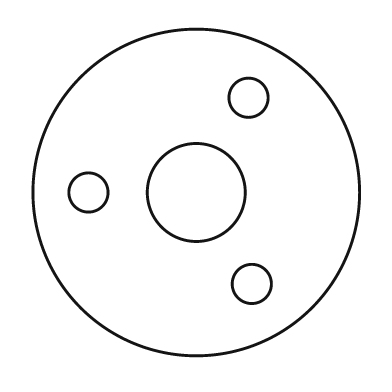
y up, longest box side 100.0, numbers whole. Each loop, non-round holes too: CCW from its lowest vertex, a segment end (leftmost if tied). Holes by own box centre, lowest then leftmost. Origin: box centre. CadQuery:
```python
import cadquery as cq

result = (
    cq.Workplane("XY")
    .moveTo(0.0, 0.0)
    .circle(50.0)
    .moveTo(17.0, -28.0)
    .circle(6.0)
    .moveTo(-33.0, 0.0)
    .circle(6.0)
    .moveTo(0.0, 0.0)
    .circle(15.0)
    .moveTo(16.0, 29.0)
    .circle(6.0)
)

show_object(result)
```